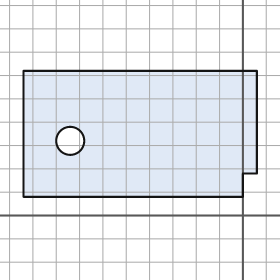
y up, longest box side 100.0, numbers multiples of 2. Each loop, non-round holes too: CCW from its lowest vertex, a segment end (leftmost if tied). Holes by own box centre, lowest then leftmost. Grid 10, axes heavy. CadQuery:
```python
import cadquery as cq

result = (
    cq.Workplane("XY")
    .moveTo(-94.0, 8.0)
    .lineTo(0.0, 8.0)
    .lineTo(0.0, 18.0)
    .lineTo(6.0, 18.0)
    .lineTo(6.0, 62.0)
    .lineTo(-94.0, 62.0)
    .close()
    .moveTo(-74.0, 32.0)
    .circle(6.0)
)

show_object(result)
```